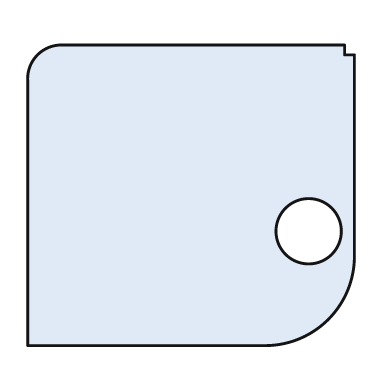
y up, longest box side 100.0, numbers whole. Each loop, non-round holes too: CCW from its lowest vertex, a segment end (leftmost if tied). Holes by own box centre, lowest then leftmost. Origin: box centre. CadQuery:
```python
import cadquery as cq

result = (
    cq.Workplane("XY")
    .moveTo(-50.0, -46.0)
    .lineTo(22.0, -46.0)
    .threePointArc((42.0, -38.0), (50.0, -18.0))
    .lineTo(50.0, 43.0)
    .lineTo(47.0, 43.0)
    .lineTo(47.0, 46.0)
    .lineTo(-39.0, 46.0)
    .threePointArc((-47.0, 43.0), (-50.0, 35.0))
    .close()
    .moveTo(36.0, -11.0)
    .circle(10.0)
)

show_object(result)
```